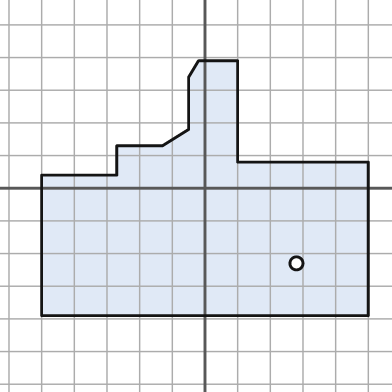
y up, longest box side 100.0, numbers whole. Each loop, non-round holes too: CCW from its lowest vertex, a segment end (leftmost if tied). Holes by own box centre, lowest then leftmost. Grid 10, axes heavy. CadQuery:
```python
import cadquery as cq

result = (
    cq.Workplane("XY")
    .moveTo(-50.0, -39.0)
    .lineTo(50.0, -39.0)
    .lineTo(50.0, 8.0)
    .lineTo(10.0, 8.0)
    .lineTo(10.0, 39.0)
    .lineTo(-2.0, 39.0)
    .lineTo(-5.0, 34.0)
    .lineTo(-5.0, 18.0)
    .lineTo(-13.0, 13.0)
    .lineTo(-27.0, 13.0)
    .lineTo(-27.0, 4.0)
    .lineTo(-50.0, 4.0)
    .close()
    .moveTo(28.0, -23.0)
    .circle(2.0)
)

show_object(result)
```